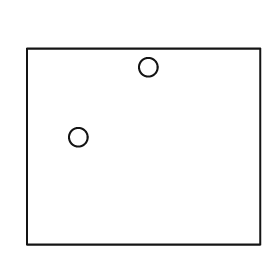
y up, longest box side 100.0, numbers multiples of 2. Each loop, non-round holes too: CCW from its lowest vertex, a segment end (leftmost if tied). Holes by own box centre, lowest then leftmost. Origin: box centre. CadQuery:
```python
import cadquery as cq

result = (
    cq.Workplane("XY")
    .moveTo(-50.0, -42.0)
    .lineTo(50.0, -42.0)
    .lineTo(50.0, 42.0)
    .lineTo(-50.0, 42.0)
    .close()
    .moveTo(-28.0, 4.0)
    .circle(4.0)
    .moveTo(2.0, 34.0)
    .circle(4.0)
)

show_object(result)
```